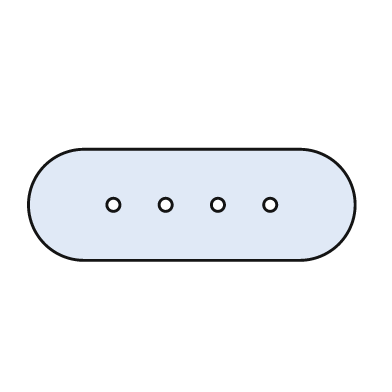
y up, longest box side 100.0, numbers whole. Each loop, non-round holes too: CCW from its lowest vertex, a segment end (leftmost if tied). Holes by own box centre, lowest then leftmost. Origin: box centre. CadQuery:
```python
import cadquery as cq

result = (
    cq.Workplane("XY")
    .moveTo(-33.0, -17.0)
    .lineTo(33.0, -17.0)
    .threePointArc((50.0, 0.0), (33.0, 17.0))
    .lineTo(-33.0, 17.0)
    .threePointArc((-50.0, 0.0), (-33.0, -17.0))
    .close()
    .moveTo(-24.0, 0.0)
    .circle(2.0)
    .moveTo(-8.0, 0.0)
    .circle(2.0)
    .moveTo(8.0, 0.0)
    .circle(2.0)
    .moveTo(24.0, 0.0)
    .circle(2.0)
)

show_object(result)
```